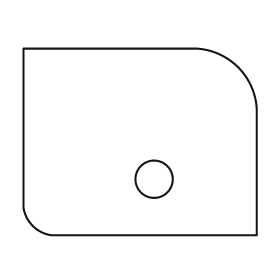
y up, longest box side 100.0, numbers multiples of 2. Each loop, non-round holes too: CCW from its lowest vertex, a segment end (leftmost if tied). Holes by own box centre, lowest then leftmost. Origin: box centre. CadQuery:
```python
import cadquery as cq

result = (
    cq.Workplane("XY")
    .moveTo(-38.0, -40.0)
    .lineTo(50.0, -40.0)
    .lineTo(50.0, 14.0)
    .threePointArc((42.0, 32.0), (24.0, 40.0))
    .lineTo(-50.0, 40.0)
    .lineTo(-50.0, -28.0)
    .threePointArc((-46.0, -36.0), (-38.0, -40.0))
    .close()
    .moveTo(6.0, -16.0)
    .circle(8.0)
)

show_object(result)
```